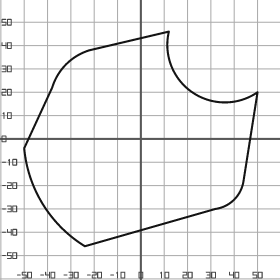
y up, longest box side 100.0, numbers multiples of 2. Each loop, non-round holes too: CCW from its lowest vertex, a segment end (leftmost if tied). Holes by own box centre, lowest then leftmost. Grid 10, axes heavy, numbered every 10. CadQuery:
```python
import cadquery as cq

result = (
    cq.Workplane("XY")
    .moveTo(-24.0, -46.0)
    .lineTo(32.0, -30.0)
    .threePointArc((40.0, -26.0), (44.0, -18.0))
    .lineTo(50.0, 20.0)
    .threePointArc((22.0, 20.0), (12.0, 46.0))
    .lineTo(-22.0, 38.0)
    .threePointArc((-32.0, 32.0), (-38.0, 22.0))
    .lineTo(-50.0, -4.0)
    .threePointArc((-42.0, -28.0), (-24.0, -46.0))
    .close()
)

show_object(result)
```